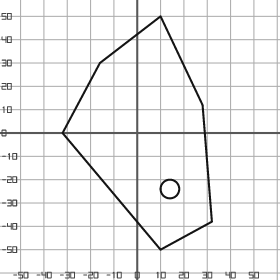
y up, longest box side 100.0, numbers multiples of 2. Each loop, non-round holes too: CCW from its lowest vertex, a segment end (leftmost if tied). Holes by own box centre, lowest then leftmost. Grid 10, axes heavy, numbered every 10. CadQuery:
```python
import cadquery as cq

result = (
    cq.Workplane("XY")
    .moveTo(10.0, -50.0)
    .lineTo(32.0, -38.0)
    .lineTo(28.0, 12.0)
    .lineTo(10.0, 50.0)
    .lineTo(-16.0, 30.0)
    .lineTo(-32.0, 0.0)
    .close()
    .moveTo(14.0, -24.0)
    .circle(4.0)
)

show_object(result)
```